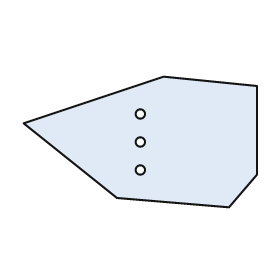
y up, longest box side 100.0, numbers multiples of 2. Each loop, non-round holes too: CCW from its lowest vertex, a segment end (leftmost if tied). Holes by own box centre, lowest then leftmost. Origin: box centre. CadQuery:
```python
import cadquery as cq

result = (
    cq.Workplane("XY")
    .moveTo(38.0, -28.0)
    .lineTo(50.0, -14.0)
    .lineTo(50.0, 24.0)
    .lineTo(10.0, 28.0)
    .lineTo(-50.0, 8.0)
    .lineTo(-10.0, -24.0)
    .close()
    .moveTo(0.0, -12.0)
    .circle(2.0)
    .moveTo(0.0, 0.0)
    .circle(2.0)
    .moveTo(0.0, 12.0)
    .circle(2.0)
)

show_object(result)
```